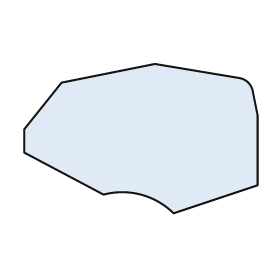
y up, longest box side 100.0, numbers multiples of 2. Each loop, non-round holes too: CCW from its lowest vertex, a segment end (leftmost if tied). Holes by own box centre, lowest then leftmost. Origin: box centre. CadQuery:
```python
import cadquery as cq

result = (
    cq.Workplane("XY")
    .moveTo(14.0, -32.0)
    .lineTo(50.0, -20.0)
    .lineTo(50.0, 10.0)
    .lineTo(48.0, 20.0)
    .threePointArc((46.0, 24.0), (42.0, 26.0))
    .lineTo(6.0, 32.0)
    .lineTo(-34.0, 24.0)
    .lineTo(-50.0, 4.0)
    .lineTo(-50.0, -6.0)
    .lineTo(-16.0, -24.0)
    .threePointArc((0.0, -24.0), (14.0, -32.0))
    .close()
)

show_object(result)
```